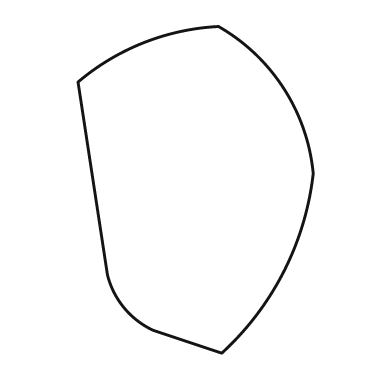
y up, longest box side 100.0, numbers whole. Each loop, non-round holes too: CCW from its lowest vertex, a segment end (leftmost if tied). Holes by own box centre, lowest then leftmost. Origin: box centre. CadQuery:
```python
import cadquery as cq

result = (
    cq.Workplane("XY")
    .moveTo(8.0, -50.0)
    .threePointArc((27.0, -25.0), (36.0, 5.0))
    .threePointArc((27.0, 31.0), (7.0, 50.0))
    .threePointArc((-16.0, 45.0), (-36.0, 33.0))
    .lineTo(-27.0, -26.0)
    .threePointArc((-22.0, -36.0), (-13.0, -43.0))
    .close()
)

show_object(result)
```